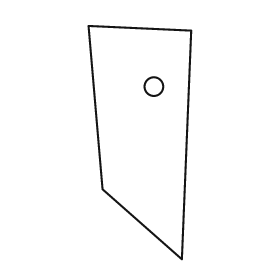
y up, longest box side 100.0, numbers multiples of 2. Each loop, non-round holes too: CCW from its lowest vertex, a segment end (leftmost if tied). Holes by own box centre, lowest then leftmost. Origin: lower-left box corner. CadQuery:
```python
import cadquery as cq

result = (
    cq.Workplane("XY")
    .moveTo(40.0, 0.0)
    .lineTo(44.0, 98.0)
    .lineTo(0.0, 100.0)
    .lineTo(6.0, 30.0)
    .close()
    .moveTo(28.0, 74.0)
    .circle(4.0)
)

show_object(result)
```